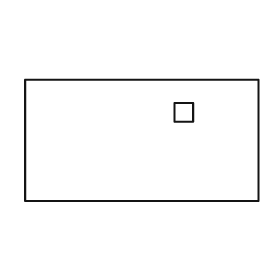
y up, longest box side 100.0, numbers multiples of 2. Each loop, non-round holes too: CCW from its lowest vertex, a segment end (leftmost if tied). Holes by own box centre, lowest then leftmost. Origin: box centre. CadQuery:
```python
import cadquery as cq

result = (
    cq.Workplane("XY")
    .moveTo(-50.0, -26.0)
    .lineTo(50.0, -26.0)
    .lineTo(50.0, 26.0)
    .lineTo(-50.0, 26.0)
    .close()
    .moveTo(14.0, 8.0)
    .lineTo(22.0, 8.0)
    .lineTo(22.0, 16.0)
    .lineTo(14.0, 16.0)
    .close()
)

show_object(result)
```